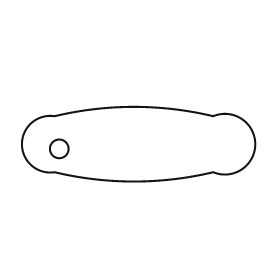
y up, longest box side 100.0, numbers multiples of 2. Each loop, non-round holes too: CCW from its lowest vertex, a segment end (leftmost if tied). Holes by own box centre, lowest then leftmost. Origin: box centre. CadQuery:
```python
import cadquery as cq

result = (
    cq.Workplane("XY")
    .moveTo(-36.0, -12.0)
    .threePointArc((-2.0, -16.0), (32.0, -12.0))
    .threePointArc((50.0, 0.0), (32.0, 12.0))
    .threePointArc((-2.0, 16.0), (-36.0, 12.0))
    .threePointArc((-50.0, 0.0), (-36.0, -12.0))
    .close()
    .moveTo(-34.0, -2.0)
    .circle(4.0)
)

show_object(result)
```